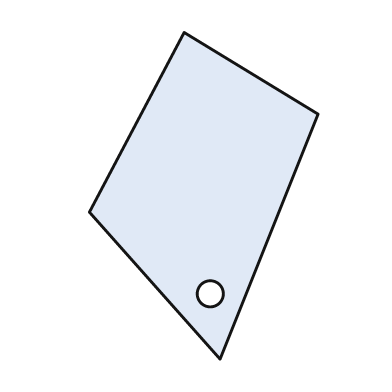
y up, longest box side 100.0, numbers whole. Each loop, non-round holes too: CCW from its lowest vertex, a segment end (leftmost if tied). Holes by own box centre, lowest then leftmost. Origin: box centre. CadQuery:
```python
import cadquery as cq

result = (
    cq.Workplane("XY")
    .moveTo(5.0, -50.0)
    .lineTo(35.0, 25.0)
    .lineTo(-6.0, 50.0)
    .lineTo(-35.0, -5.0)
    .close()
    .moveTo(2.0, -30.0)
    .circle(4.0)
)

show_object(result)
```